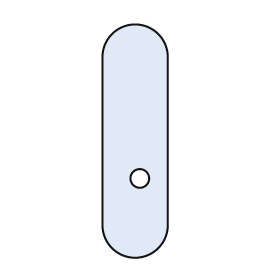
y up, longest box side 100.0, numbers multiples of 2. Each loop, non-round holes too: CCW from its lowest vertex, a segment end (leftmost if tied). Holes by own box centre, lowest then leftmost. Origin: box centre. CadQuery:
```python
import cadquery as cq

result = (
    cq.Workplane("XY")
    .moveTo(-14.0, -36.0)
    .threePointArc((0.0, -50.0), (14.0, -36.0))
    .lineTo(14.0, 36.0)
    .threePointArc((0.0, 50.0), (-14.0, 36.0))
    .close()
    .moveTo(2.0, -16.0)
    .circle(4.0)
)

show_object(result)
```